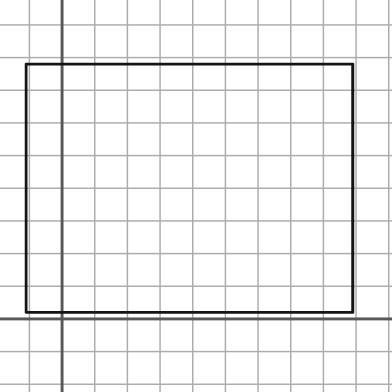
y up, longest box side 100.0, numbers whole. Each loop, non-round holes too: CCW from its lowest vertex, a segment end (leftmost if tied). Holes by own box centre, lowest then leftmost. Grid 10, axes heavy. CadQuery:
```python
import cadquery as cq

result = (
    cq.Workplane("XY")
    .moveTo(-11.0, 2.0)
    .lineTo(89.0, 2.0)
    .lineTo(89.0, 78.0)
    .lineTo(-11.0, 78.0)
    .close()
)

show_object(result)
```